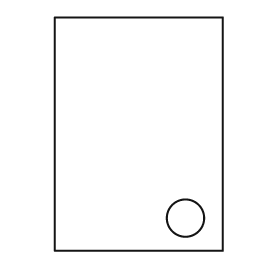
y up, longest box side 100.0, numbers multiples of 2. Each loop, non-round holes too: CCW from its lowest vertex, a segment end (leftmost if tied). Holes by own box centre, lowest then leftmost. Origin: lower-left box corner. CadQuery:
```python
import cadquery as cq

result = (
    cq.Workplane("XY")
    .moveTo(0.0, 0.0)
    .lineTo(72.0, 0.0)
    .lineTo(72.0, 100.0)
    .lineTo(0.0, 100.0)
    .close()
    .moveTo(56.0, 14.0)
    .circle(8.0)
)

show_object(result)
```